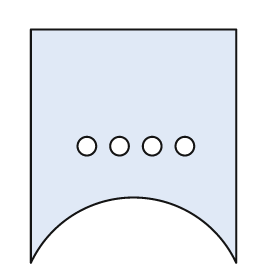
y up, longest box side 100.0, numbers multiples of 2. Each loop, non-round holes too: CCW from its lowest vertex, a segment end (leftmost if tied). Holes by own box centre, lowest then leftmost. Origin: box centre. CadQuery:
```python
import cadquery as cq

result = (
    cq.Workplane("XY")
    .moveTo(-44.0, -50.0)
    .threePointArc((0.0, -22.0), (44.0, -50.0))
    .lineTo(44.0, 50.0)
    .lineTo(-44.0, 50.0)
    .close()
    .moveTo(-20.0, 0.0)
    .circle(4.0)
    .moveTo(-6.0, 0.0)
    .circle(4.0)
    .moveTo(8.0, 0.0)
    .circle(4.0)
    .moveTo(22.0, 0.0)
    .circle(4.0)
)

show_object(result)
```